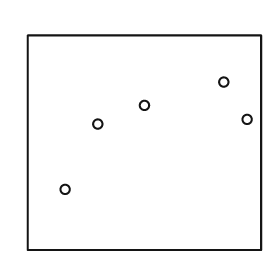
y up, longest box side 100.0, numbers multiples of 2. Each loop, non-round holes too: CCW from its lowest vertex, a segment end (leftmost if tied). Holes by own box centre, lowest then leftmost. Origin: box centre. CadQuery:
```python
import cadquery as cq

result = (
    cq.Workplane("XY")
    .moveTo(-50.0, -46.0)
    .lineTo(50.0, -46.0)
    .lineTo(50.0, 46.0)
    .lineTo(-50.0, 46.0)
    .close()
    .moveTo(-34.0, -20.0)
    .circle(2.0)
    .moveTo(-20.0, 8.0)
    .circle(2.0)
    .moveTo(44.0, 10.0)
    .circle(2.0)
    .moveTo(0.0, 16.0)
    .circle(2.0)
    .moveTo(34.0, 26.0)
    .circle(2.0)
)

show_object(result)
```